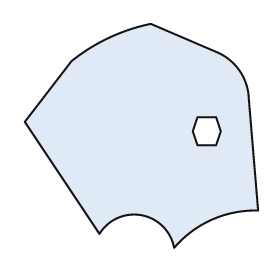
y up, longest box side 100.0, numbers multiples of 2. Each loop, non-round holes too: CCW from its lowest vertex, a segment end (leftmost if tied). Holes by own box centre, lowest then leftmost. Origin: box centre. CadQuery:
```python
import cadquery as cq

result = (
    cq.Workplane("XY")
    .moveTo(14.0, -48.0)
    .threePointArc((30.0, -36.0), (50.0, -32.0))
    .lineTo(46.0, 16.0)
    .threePointArc((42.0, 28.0), (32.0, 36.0))
    .lineTo(4.0, 48.0)
    .threePointArc((-14.0, 42.0), (-30.0, 32.0))
    .lineTo(-50.0, 6.0)
    .lineTo(-18.0, -42.0)
    .threePointArc((0.0, -34.0), (14.0, -48.0))
    .close()
    .moveTo(24.0, -4.0)
    .lineTo(32.0, -4.0)
    .lineTo(34.0, 2.0)
    .lineTo(32.0, 8.0)
    .lineTo(24.0, 8.0)
    .lineTo(22.0, 2.0)
    .close()
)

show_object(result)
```